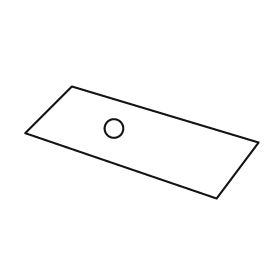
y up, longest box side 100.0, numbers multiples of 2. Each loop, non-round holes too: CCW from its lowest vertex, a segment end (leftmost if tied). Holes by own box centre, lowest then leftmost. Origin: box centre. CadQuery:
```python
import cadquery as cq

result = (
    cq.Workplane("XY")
    .moveTo(32.0, -24.0)
    .lineTo(50.0, 0.0)
    .lineTo(-30.0, 24.0)
    .lineTo(-50.0, 4.0)
    .close()
    .moveTo(-12.0, 6.0)
    .circle(4.0)
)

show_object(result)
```